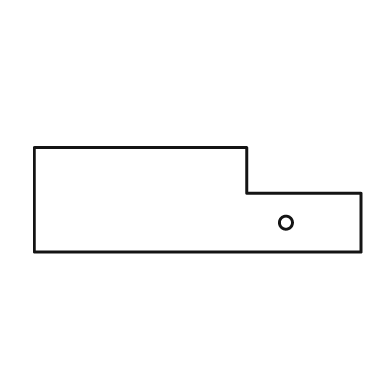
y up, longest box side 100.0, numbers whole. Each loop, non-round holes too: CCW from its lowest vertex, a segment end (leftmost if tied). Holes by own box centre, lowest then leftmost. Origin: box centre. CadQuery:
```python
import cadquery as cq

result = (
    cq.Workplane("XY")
    .moveTo(-50.0, -16.0)
    .lineTo(50.0, -16.0)
    .lineTo(50.0, 2.0)
    .lineTo(15.0, 2.0)
    .lineTo(15.0, 16.0)
    .lineTo(-50.0, 16.0)
    .close()
    .moveTo(27.0, -7.0)
    .circle(2.0)
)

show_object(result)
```